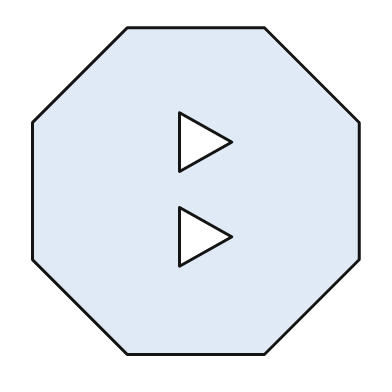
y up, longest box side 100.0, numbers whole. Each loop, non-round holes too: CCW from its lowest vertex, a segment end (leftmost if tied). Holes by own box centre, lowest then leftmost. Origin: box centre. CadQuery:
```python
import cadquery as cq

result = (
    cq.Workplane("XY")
    .moveTo(-21.0, -50.0)
    .lineTo(21.0, -50.0)
    .lineTo(50.0, -21.0)
    .lineTo(50.0, 21.0)
    .lineTo(21.0, 50.0)
    .lineTo(-21.0, 50.0)
    .lineTo(-50.0, 21.0)
    .lineTo(-50.0, -21.0)
    .close()
    .moveTo(-5.0, -23.0)
    .lineTo(11.0, -14.0)
    .lineTo(-5.0, -5.0)
    .close()
    .moveTo(-5.0, 6.0)
    .lineTo(11.0, 15.0)
    .lineTo(-5.0, 24.0)
    .close()
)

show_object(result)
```